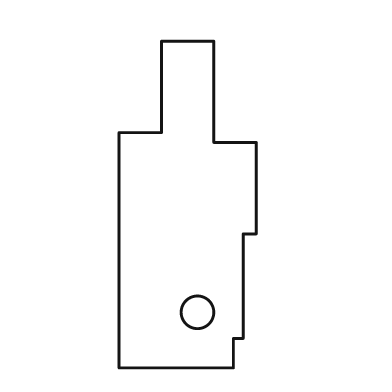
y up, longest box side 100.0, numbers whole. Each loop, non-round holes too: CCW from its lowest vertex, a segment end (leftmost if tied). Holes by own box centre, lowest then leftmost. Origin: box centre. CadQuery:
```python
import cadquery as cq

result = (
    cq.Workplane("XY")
    .moveTo(-21.0, -50.0)
    .lineTo(14.0, -50.0)
    .lineTo(14.0, -41.0)
    .lineTo(17.0, -41.0)
    .lineTo(17.0, -9.0)
    .lineTo(21.0, -9.0)
    .lineTo(21.0, 19.0)
    .lineTo(8.0, 19.0)
    .lineTo(8.0, 50.0)
    .lineTo(-8.0, 50.0)
    .lineTo(-8.0, 22.0)
    .lineTo(-21.0, 22.0)
    .close()
    .moveTo(3.0, -33.0)
    .circle(5.0)
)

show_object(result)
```